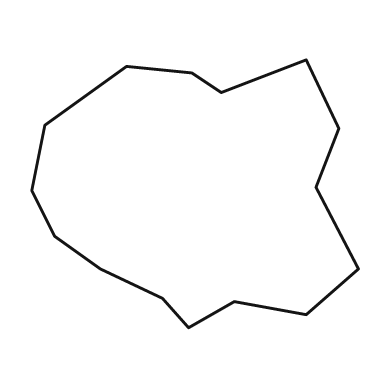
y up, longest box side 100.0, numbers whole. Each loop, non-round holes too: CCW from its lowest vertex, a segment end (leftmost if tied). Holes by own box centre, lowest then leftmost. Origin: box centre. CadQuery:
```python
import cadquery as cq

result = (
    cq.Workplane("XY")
    .moveTo(-2.0, -41.0)
    .lineTo(12.0, -33.0)
    .lineTo(34.0, -37.0)
    .lineTo(50.0, -23.0)
    .lineTo(37.0, 2.0)
    .lineTo(44.0, 20.0)
    .lineTo(34.0, 41.0)
    .lineTo(8.0, 31.0)
    .lineTo(-1.0, 37.0)
    .lineTo(-21.0, 39.0)
    .lineTo(-46.0, 21.0)
    .lineTo(-50.0, 1.0)
    .lineTo(-43.0, -13.0)
    .lineTo(-29.0, -23.0)
    .lineTo(-10.0, -32.0)
    .close()
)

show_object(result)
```